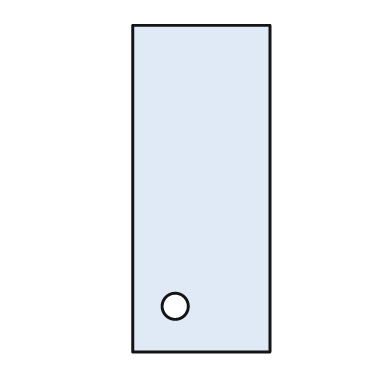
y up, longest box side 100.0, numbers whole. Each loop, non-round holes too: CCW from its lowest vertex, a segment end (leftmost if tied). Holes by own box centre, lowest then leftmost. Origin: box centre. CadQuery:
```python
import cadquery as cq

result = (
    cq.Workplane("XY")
    .moveTo(-21.0, -50.0)
    .lineTo(21.0, -50.0)
    .lineTo(21.0, 50.0)
    .lineTo(-21.0, 50.0)
    .close()
    .moveTo(-8.0, -36.0)
    .circle(4.0)
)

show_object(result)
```